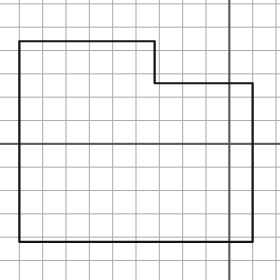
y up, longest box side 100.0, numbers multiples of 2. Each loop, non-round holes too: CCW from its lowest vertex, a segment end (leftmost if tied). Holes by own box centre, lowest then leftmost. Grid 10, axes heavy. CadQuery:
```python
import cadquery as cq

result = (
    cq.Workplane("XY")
    .moveTo(-90.0, -42.0)
    .lineTo(10.0, -42.0)
    .lineTo(10.0, 26.0)
    .lineTo(-32.0, 26.0)
    .lineTo(-32.0, 44.0)
    .lineTo(-90.0, 44.0)
    .close()
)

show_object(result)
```